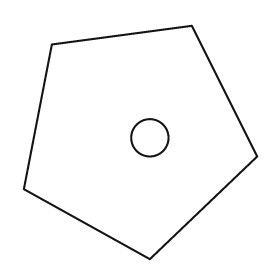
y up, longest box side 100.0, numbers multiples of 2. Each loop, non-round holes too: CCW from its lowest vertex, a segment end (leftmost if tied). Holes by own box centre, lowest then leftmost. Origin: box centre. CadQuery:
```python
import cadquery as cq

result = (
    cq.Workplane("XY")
    .moveTo(4.0, -50.0)
    .lineTo(50.0, -6.0)
    .lineTo(22.0, 50.0)
    .lineTo(-38.0, 42.0)
    .lineTo(-50.0, -20.0)
    .close()
    .moveTo(4.0, 2.0)
    .circle(8.0)
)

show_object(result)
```